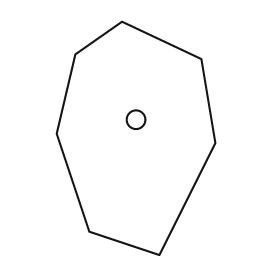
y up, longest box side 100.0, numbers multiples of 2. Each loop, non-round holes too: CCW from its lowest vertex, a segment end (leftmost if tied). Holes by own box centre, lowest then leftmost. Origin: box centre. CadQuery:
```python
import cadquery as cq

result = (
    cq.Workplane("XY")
    .moveTo(10.0, -50.0)
    .lineTo(34.0, -2.0)
    .lineTo(28.0, 34.0)
    .lineTo(-6.0, 50.0)
    .lineTo(-26.0, 36.0)
    .lineTo(-34.0, 2.0)
    .lineTo(-20.0, -40.0)
    .close()
    .moveTo(0.0, 8.0)
    .circle(4.0)
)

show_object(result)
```